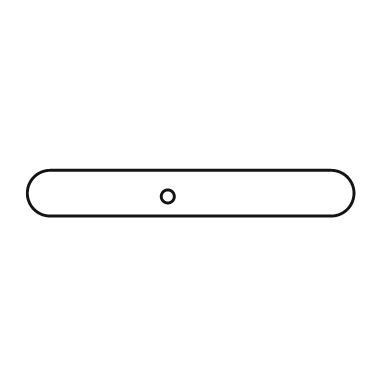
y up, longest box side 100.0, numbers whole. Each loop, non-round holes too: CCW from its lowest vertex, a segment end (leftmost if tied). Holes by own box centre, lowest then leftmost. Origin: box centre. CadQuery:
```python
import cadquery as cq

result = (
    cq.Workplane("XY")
    .moveTo(-43.0, -7.0)
    .lineTo(43.0, -7.0)
    .threePointArc((50.0, 0.0), (43.0, 7.0))
    .lineTo(-43.0, 7.0)
    .threePointArc((-50.0, 0.0), (-43.0, -7.0))
    .close()
    .moveTo(-7.0, -1.0)
    .circle(2.0)
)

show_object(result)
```